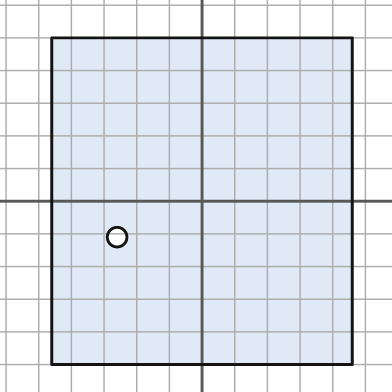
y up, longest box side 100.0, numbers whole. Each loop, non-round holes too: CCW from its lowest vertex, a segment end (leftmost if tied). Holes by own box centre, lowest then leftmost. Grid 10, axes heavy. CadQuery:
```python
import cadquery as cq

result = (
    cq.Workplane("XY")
    .moveTo(-46.0, -50.0)
    .lineTo(46.0, -50.0)
    .lineTo(46.0, 50.0)
    .lineTo(-46.0, 50.0)
    .close()
    .moveTo(-26.0, -11.0)
    .circle(3.0)
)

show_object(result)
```